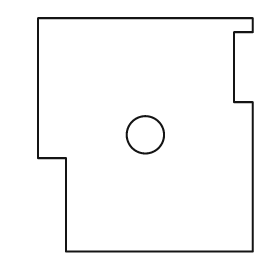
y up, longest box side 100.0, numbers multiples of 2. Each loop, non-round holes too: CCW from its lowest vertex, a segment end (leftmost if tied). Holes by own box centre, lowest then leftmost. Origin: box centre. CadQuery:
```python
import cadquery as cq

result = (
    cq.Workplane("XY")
    .moveTo(-34.0, -50.0)
    .lineTo(46.0, -50.0)
    .lineTo(46.0, 14.0)
    .lineTo(38.0, 14.0)
    .lineTo(38.0, 44.0)
    .lineTo(46.0, 44.0)
    .lineTo(46.0, 50.0)
    .lineTo(-46.0, 50.0)
    .lineTo(-46.0, -10.0)
    .lineTo(-34.0, -10.0)
    .close()
    .moveTo(0.0, 0.0)
    .circle(8.0)
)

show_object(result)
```